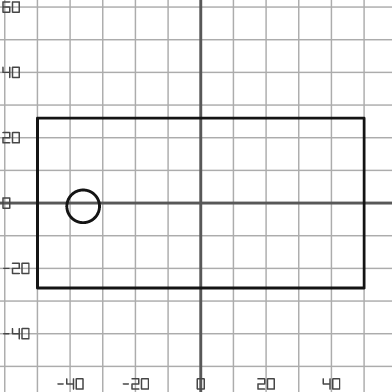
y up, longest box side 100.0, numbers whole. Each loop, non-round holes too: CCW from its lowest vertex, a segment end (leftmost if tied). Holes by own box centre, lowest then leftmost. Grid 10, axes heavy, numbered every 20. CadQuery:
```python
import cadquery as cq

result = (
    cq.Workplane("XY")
    .moveTo(-50.0, -26.0)
    .lineTo(50.0, -26.0)
    .lineTo(50.0, 26.0)
    .lineTo(-50.0, 26.0)
    .close()
    .moveTo(-36.0, -1.0)
    .circle(5.0)
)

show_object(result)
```